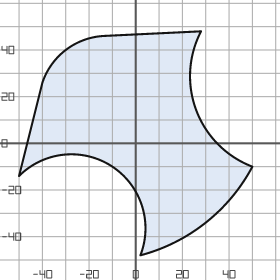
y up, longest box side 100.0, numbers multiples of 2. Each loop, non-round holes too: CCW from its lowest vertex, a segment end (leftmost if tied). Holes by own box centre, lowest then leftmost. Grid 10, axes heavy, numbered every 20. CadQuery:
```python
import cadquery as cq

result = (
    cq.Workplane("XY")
    .moveTo(2.0, -48.0)
    .threePointArc((30.0, -34.0), (50.0, -10.0))
    .threePointArc((26.0, 14.0), (28.0, 48.0))
    .lineTo(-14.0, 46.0)
    .threePointArc((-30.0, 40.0), (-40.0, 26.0))
    .lineTo(-50.0, -14.0)
    .threePointArc((-10.0, -10.0), (2.0, -48.0))
    .close()
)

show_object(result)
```